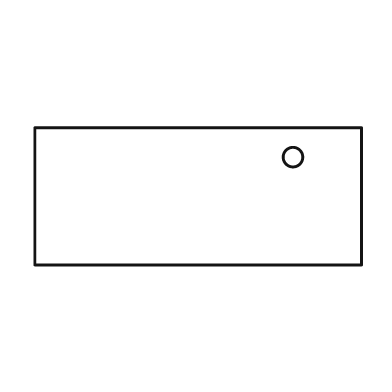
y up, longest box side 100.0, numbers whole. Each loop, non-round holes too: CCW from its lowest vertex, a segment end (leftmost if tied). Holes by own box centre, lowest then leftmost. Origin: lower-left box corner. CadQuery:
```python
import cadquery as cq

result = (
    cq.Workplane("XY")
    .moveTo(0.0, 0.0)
    .lineTo(100.0, 0.0)
    .lineTo(100.0, 42.0)
    .lineTo(0.0, 42.0)
    .close()
    .moveTo(79.0, 33.0)
    .circle(3.0)
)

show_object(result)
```